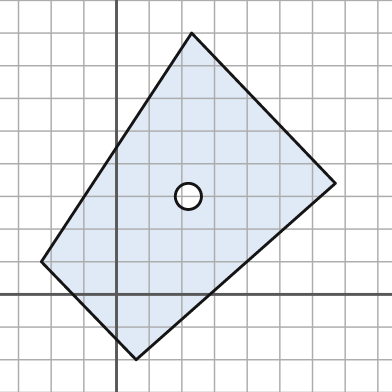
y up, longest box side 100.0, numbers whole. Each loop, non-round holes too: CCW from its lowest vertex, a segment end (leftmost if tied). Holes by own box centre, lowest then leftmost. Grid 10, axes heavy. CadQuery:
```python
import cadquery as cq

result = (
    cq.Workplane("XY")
    .moveTo(6.0, -20.0)
    .lineTo(67.0, 34.0)
    .lineTo(23.0, 80.0)
    .lineTo(-23.0, 10.0)
    .close()
    .moveTo(22.0, 30.0)
    .circle(4.0)
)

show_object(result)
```